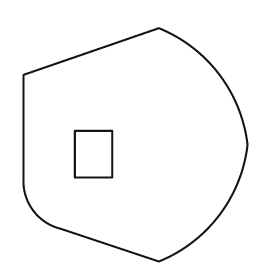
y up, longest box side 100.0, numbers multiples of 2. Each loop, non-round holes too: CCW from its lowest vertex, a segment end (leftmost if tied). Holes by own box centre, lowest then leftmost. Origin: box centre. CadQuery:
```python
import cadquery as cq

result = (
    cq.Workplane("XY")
    .moveTo(10.0, -50.0)
    .threePointArc((36.0, -30.0), (48.0, 0.0))
    .threePointArc((36.0, 30.0), (10.0, 50.0))
    .lineTo(-48.0, 30.0)
    .lineTo(-48.0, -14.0)
    .threePointArc((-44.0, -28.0), (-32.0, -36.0))
    .close()
    .moveTo(-26.0, -14.0)
    .lineTo(-10.0, -14.0)
    .lineTo(-10.0, 6.0)
    .lineTo(-26.0, 6.0)
    .close()
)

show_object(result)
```